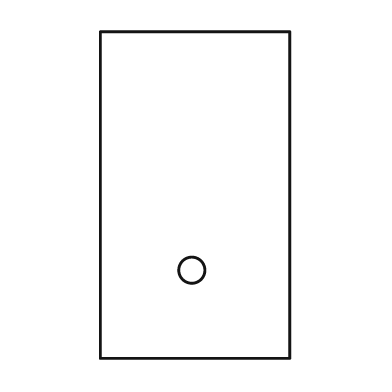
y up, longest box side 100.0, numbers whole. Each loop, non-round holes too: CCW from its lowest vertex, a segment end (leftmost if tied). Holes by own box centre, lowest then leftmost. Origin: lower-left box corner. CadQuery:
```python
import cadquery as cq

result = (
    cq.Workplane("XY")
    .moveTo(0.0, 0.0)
    .lineTo(58.0, 0.0)
    .lineTo(58.0, 100.0)
    .lineTo(0.0, 100.0)
    .close()
    .moveTo(28.0, 27.0)
    .circle(4.0)
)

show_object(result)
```